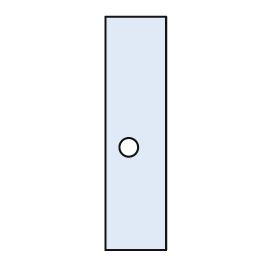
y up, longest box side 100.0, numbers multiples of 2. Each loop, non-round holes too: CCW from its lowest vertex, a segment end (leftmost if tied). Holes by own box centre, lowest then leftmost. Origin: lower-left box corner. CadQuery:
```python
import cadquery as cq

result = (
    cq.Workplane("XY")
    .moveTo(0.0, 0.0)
    .lineTo(26.0, 0.0)
    .lineTo(26.0, 100.0)
    .lineTo(0.0, 100.0)
    .close()
    .moveTo(10.0, 44.0)
    .circle(4.0)
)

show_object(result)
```